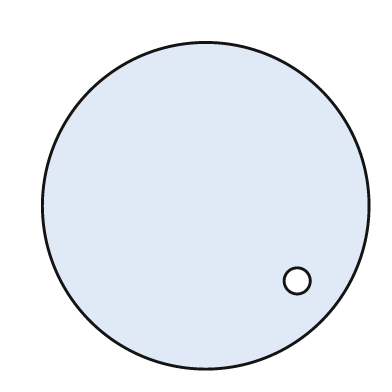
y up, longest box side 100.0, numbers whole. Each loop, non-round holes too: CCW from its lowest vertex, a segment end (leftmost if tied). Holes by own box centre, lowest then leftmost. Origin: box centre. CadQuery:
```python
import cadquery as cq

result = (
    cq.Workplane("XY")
    .moveTo(0.0, 0.0)
    .circle(50.0)
    .moveTo(28.0, -23.0)
    .circle(4.0)
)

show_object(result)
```